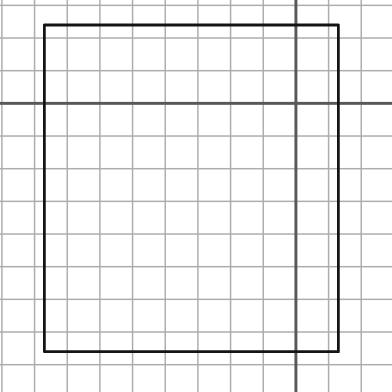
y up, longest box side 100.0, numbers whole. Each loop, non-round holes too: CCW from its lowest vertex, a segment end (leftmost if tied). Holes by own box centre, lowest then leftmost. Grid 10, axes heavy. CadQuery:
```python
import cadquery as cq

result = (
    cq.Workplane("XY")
    .moveTo(-77.0, -76.0)
    .lineTo(13.0, -76.0)
    .lineTo(13.0, 24.0)
    .lineTo(-77.0, 24.0)
    .close()
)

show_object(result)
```